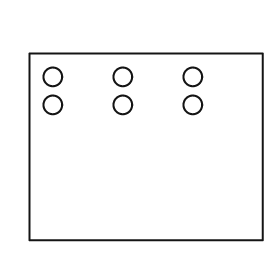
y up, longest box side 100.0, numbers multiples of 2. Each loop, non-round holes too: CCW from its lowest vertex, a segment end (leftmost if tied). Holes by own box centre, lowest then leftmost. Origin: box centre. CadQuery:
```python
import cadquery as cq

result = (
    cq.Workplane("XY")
    .moveTo(-50.0, -40.0)
    .lineTo(50.0, -40.0)
    .lineTo(50.0, 40.0)
    .lineTo(-50.0, 40.0)
    .close()
    .moveTo(-40.0, 18.0)
    .circle(4.0)
    .moveTo(-10.0, 18.0)
    .circle(4.0)
    .moveTo(20.0, 18.0)
    .circle(4.0)
    .moveTo(-40.0, 30.0)
    .circle(4.0)
    .moveTo(-10.0, 30.0)
    .circle(4.0)
    .moveTo(20.0, 30.0)
    .circle(4.0)
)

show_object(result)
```